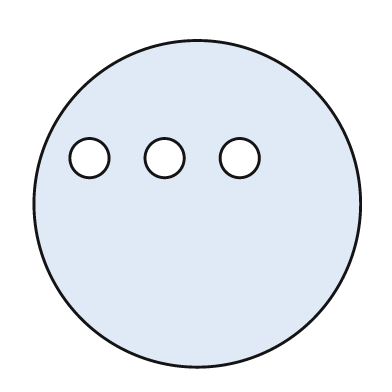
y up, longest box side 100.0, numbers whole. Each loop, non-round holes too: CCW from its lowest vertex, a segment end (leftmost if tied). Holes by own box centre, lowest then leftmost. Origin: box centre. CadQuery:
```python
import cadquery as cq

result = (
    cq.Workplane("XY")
    .moveTo(0.0, 0.0)
    .circle(50.0)
    .moveTo(-33.0, 14.0)
    .circle(6.0)
    .moveTo(-10.0, 14.0)
    .circle(6.0)
    .moveTo(13.0, 14.0)
    .circle(6.0)
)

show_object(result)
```